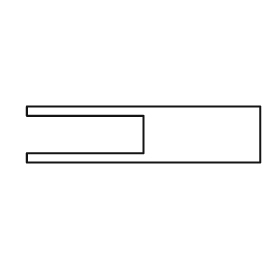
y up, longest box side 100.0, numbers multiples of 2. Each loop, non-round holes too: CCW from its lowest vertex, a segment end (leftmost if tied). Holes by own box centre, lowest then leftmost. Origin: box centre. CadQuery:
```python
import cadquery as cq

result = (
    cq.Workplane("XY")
    .moveTo(-50.0, -12.0)
    .lineTo(50.0, -12.0)
    .lineTo(50.0, 12.0)
    .lineTo(-50.0, 12.0)
    .lineTo(-50.0, 8.0)
    .lineTo(0.0, 8.0)
    .lineTo(0.0, -8.0)
    .lineTo(-50.0, -8.0)
    .close()
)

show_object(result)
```